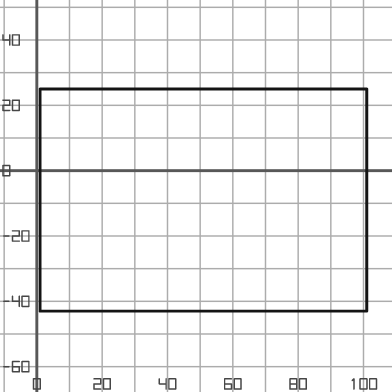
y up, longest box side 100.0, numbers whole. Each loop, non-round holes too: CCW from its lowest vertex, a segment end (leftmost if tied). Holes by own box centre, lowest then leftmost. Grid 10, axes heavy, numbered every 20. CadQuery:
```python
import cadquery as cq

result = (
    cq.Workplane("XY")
    .moveTo(1.0, -43.0)
    .lineTo(101.0, -43.0)
    .lineTo(101.0, 25.0)
    .lineTo(1.0, 25.0)
    .close()
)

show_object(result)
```